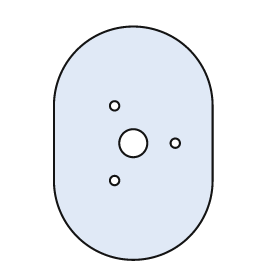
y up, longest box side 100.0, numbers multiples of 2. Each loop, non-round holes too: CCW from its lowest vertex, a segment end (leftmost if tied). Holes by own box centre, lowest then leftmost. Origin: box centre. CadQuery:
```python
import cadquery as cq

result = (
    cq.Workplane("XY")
    .moveTo(-34.0, -16.0)
    .threePointArc((0.0, -50.0), (34.0, -16.0))
    .lineTo(34.0, 16.0)
    .threePointArc((0.0, 50.0), (-34.0, 16.0))
    .close()
    .moveTo(-8.0, -16.0)
    .circle(2.0)
    .moveTo(0.0, 0.0)
    .circle(6.0)
    .moveTo(18.0, 0.0)
    .circle(2.0)
    .moveTo(-8.0, 16.0)
    .circle(2.0)
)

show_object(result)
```